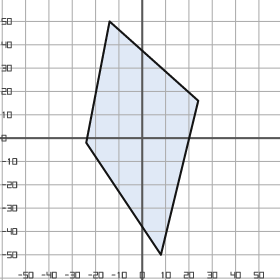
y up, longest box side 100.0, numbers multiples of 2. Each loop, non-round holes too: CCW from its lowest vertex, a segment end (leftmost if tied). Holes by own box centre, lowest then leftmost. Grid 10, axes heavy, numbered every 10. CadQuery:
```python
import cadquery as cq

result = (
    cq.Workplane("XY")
    .moveTo(8.0, -50.0)
    .lineTo(24.0, 16.0)
    .lineTo(-14.0, 50.0)
    .lineTo(-24.0, -2.0)
    .close()
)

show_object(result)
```